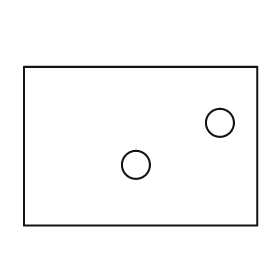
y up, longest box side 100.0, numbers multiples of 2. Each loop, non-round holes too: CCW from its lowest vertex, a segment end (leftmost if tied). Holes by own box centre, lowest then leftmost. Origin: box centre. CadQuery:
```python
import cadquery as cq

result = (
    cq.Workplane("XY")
    .moveTo(-50.0, -34.0)
    .lineTo(50.0, -34.0)
    .lineTo(50.0, 34.0)
    .lineTo(-50.0, 34.0)
    .close()
    .moveTo(-2.0, -8.0)
    .circle(6.0)
    .moveTo(34.0, 10.0)
    .circle(6.0)
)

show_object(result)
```